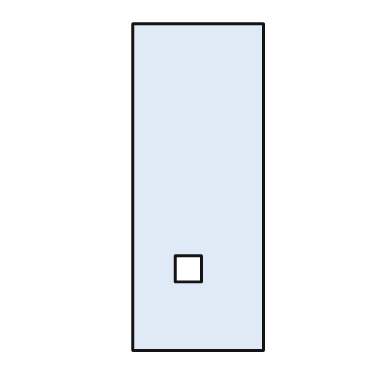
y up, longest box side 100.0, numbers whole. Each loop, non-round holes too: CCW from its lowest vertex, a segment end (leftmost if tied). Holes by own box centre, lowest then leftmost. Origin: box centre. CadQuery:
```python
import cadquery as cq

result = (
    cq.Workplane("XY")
    .moveTo(-20.0, -50.0)
    .lineTo(20.0, -50.0)
    .lineTo(20.0, 50.0)
    .lineTo(-20.0, 50.0)
    .close()
    .moveTo(-7.0, -29.0)
    .lineTo(1.0, -29.0)
    .lineTo(1.0, -21.0)
    .lineTo(-7.0, -21.0)
    .close()
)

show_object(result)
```